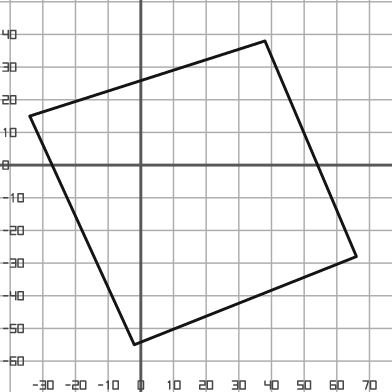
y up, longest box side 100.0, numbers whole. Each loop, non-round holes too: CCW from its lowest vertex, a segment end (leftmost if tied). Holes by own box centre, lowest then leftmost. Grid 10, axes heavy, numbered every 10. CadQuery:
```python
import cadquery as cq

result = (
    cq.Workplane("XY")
    .moveTo(-2.0, -55.0)
    .lineTo(66.0, -28.0)
    .lineTo(38.0, 38.0)
    .lineTo(-34.0, 15.0)
    .close()
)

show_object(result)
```